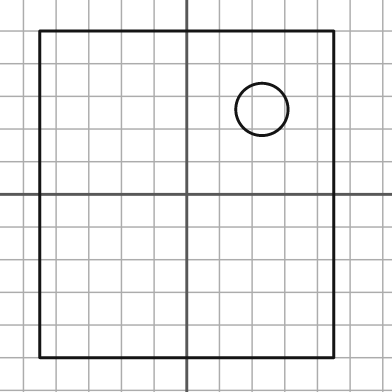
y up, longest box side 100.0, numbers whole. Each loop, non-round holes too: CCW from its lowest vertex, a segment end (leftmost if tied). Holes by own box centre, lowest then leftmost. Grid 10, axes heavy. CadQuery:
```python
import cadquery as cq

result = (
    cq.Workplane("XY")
    .moveTo(-45.0, -50.0)
    .lineTo(45.0, -50.0)
    .lineTo(45.0, 50.0)
    .lineTo(-45.0, 50.0)
    .close()
    .moveTo(23.0, 26.0)
    .circle(8.0)
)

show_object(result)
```